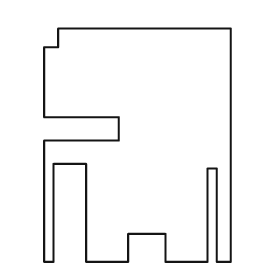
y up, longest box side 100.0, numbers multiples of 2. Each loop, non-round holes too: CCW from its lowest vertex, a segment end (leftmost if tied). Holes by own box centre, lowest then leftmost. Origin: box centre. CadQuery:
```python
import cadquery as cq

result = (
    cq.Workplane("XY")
    .moveTo(-40.0, -50.0)
    .lineTo(-36.0, -50.0)
    .lineTo(-36.0, -8.0)
    .lineTo(-22.0, -8.0)
    .lineTo(-22.0, -50.0)
    .lineTo(-4.0, -50.0)
    .lineTo(-4.0, -38.0)
    .lineTo(12.0, -38.0)
    .lineTo(12.0, -50.0)
    .lineTo(30.0, -50.0)
    .lineTo(30.0, -10.0)
    .lineTo(34.0, -10.0)
    .lineTo(34.0, -50.0)
    .lineTo(40.0, -50.0)
    .lineTo(40.0, 50.0)
    .lineTo(-34.0, 50.0)
    .lineTo(-34.0, 42.0)
    .lineTo(-40.0, 42.0)
    .lineTo(-40.0, 12.0)
    .lineTo(-8.0, 12.0)
    .lineTo(-8.0, 2.0)
    .lineTo(-40.0, 2.0)
    .close()
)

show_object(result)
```